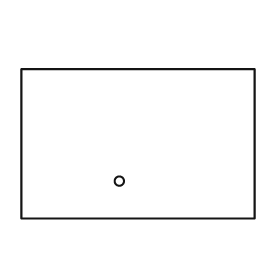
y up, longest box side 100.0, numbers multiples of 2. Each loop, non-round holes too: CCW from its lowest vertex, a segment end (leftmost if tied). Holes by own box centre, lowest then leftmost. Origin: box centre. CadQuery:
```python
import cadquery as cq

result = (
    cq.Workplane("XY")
    .moveTo(-50.0, -32.0)
    .lineTo(50.0, -32.0)
    .lineTo(50.0, 32.0)
    .lineTo(-50.0, 32.0)
    .close()
    .moveTo(-8.0, -16.0)
    .circle(2.0)
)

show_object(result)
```